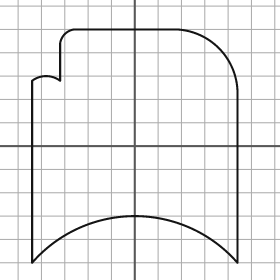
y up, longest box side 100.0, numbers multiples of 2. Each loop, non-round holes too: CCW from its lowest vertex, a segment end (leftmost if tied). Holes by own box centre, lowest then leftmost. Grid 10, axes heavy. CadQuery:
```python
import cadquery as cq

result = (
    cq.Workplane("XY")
    .moveTo(-44.0, -50.0)
    .threePointArc((0.0, -30.0), (44.0, -50.0))
    .lineTo(44.0, 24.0)
    .threePointArc((36.0, 42.0), (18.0, 50.0))
    .lineTo(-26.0, 50.0)
    .threePointArc((-30.0, 48.0), (-32.0, 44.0))
    .lineTo(-32.0, 28.0)
    .threePointArc((-38.0, 30.0), (-44.0, 28.0))
    .close()
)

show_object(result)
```